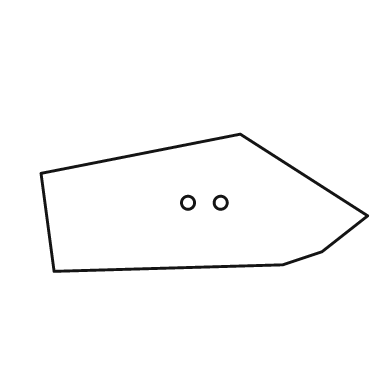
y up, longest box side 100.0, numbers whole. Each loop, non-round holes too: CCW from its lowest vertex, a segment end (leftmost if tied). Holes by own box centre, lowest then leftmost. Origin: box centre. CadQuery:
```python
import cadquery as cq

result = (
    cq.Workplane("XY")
    .moveTo(-46.0, -21.0)
    .lineTo(24.0, -19.0)
    .lineTo(36.0, -15.0)
    .lineTo(50.0, -4.0)
    .lineTo(11.0, 21.0)
    .lineTo(-50.0, 9.0)
    .close()
    .moveTo(-5.0, 0.0)
    .circle(2.0)
    .moveTo(5.0, 0.0)
    .circle(2.0)
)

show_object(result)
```